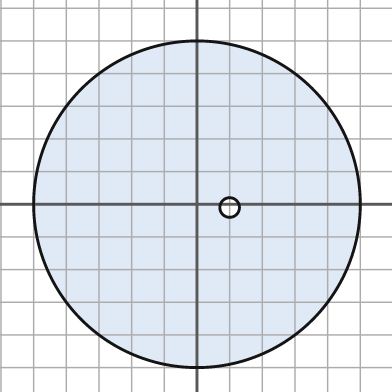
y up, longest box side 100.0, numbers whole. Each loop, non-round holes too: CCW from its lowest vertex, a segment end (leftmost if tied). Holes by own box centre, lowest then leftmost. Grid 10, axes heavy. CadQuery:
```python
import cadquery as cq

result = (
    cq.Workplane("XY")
    .moveTo(0.0, 0.0)
    .circle(50.0)
    .moveTo(10.0, -1.0)
    .circle(3.0)
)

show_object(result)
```